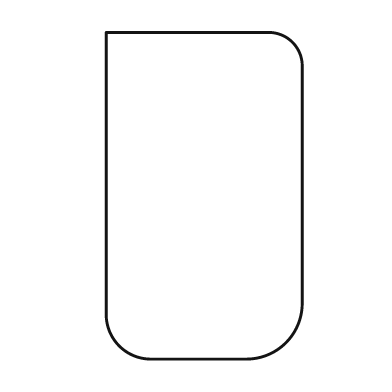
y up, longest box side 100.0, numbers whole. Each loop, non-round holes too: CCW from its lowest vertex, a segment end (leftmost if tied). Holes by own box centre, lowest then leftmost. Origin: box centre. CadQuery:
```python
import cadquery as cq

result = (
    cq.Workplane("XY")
    .moveTo(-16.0, -50.0)
    .lineTo(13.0, -50.0)
    .threePointArc((25.0, -45.0), (30.0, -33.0))
    .lineTo(30.0, 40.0)
    .threePointArc((27.0, 47.0), (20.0, 50.0))
    .lineTo(-30.0, 50.0)
    .lineTo(-30.0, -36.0)
    .threePointArc((-26.0, -46.0), (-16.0, -50.0))
    .close()
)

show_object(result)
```